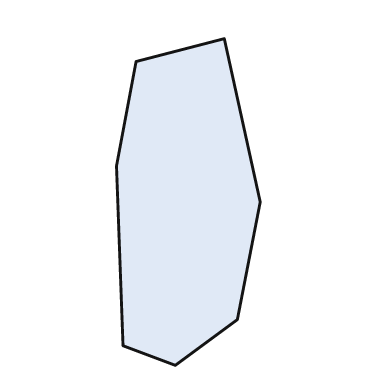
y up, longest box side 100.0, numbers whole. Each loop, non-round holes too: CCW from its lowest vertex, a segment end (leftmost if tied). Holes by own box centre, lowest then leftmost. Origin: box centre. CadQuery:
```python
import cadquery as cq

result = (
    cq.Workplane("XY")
    .moveTo(-4.0, -50.0)
    .lineTo(15.0, -36.0)
    .lineTo(22.0, 0.0)
    .lineTo(11.0, 50.0)
    .lineTo(-16.0, 43.0)
    .lineTo(-22.0, 11.0)
    .lineTo(-20.0, -44.0)
    .close()
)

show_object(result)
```